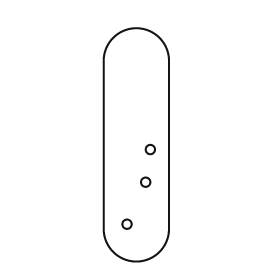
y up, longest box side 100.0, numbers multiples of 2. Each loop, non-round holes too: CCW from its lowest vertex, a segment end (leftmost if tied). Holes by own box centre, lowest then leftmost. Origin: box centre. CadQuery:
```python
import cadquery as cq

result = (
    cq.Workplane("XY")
    .moveTo(-14.0, -36.0)
    .threePointArc((0.0, -50.0), (14.0, -36.0))
    .lineTo(14.0, 36.0)
    .threePointArc((0.0, 50.0), (-14.0, 36.0))
    .close()
    .moveTo(-4.0, -34.0)
    .circle(2.0)
    .moveTo(4.0, -16.0)
    .circle(2.0)
    .moveTo(6.0, -2.0)
    .circle(2.0)
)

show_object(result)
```